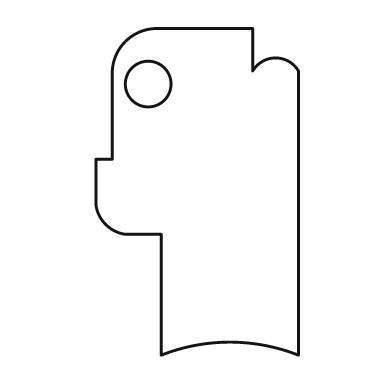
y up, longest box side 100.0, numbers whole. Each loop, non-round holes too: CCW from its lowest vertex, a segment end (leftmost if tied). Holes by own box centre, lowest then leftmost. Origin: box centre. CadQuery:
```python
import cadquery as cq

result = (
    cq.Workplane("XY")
    .moveTo(-11.0, -50.0)
    .threePointArc((10.0, -46.0), (31.0, -50.0))
    .lineTo(31.0, 37.0)
    .threePointArc((24.0, 41.0), (17.0, 37.0))
    .lineTo(17.0, 50.0)
    .lineTo(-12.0, 50.0)
    .threePointArc((-22.0, 46.0), (-26.0, 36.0))
    .lineTo(-26.0, 10.0)
    .lineTo(-31.0, 10.0)
    .lineTo(-31.0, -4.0)
    .threePointArc((-28.0, -10.0), (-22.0, -13.0))
    .lineTo(-11.0, -13.0)
    .close()
    .moveTo(-15.0, 33.0)
    .circle(7.0)
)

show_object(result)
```